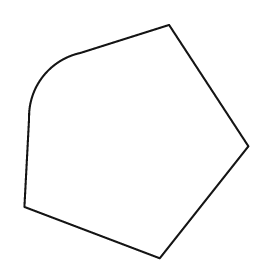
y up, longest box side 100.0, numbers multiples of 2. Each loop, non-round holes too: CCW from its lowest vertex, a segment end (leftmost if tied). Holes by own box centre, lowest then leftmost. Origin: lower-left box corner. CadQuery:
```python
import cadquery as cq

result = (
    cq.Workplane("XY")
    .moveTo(58.0, 0.0)
    .lineTo(96.0, 48.0)
    .lineTo(62.0, 100.0)
    .lineTo(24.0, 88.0)
    .threePointArc((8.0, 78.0), (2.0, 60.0))
    .lineTo(0.0, 22.0)
    .close()
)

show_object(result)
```